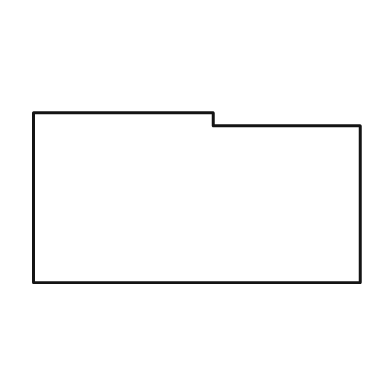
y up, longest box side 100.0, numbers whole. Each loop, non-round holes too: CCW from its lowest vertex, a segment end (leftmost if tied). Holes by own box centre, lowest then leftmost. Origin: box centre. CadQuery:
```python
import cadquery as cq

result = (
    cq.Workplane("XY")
    .moveTo(-50.0, -26.0)
    .lineTo(50.0, -26.0)
    .lineTo(50.0, 22.0)
    .lineTo(5.0, 22.0)
    .lineTo(5.0, 26.0)
    .lineTo(-50.0, 26.0)
    .close()
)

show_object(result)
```